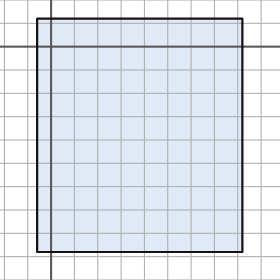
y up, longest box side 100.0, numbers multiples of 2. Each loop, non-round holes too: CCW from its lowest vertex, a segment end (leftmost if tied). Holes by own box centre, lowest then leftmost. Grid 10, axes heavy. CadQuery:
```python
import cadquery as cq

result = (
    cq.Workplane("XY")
    .moveTo(-6.0, -88.0)
    .lineTo(82.0, -88.0)
    .lineTo(82.0, 12.0)
    .lineTo(-6.0, 12.0)
    .close()
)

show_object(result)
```